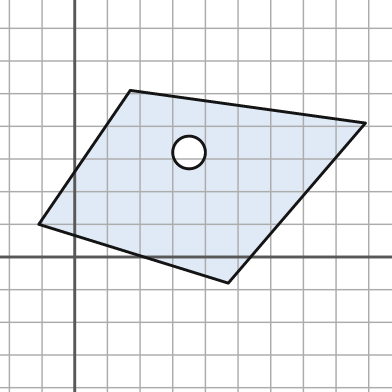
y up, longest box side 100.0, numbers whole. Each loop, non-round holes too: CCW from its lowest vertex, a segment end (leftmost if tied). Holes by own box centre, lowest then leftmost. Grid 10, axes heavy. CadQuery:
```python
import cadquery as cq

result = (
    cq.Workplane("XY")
    .moveTo(47.0, -8.0)
    .lineTo(89.0, 41.0)
    .lineTo(17.0, 51.0)
    .lineTo(-11.0, 10.0)
    .close()
    .moveTo(35.0, 32.0)
    .circle(5.0)
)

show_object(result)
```